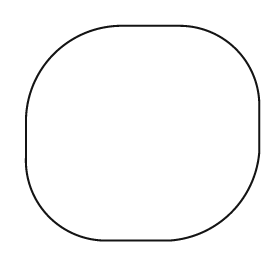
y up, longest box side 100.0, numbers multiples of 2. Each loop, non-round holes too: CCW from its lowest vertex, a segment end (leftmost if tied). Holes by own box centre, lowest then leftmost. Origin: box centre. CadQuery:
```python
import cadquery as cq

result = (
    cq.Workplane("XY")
    .moveTo(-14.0, -46.0)
    .lineTo(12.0, -46.0)
    .threePointArc((38.0, -34.0), (50.0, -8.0))
    .lineTo(50.0, 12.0)
    .threePointArc((40.0, 36.0), (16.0, 46.0))
    .lineTo(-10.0, 46.0)
    .threePointArc((-38.0, 34.0), (-50.0, 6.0))
    .lineTo(-50.0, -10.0)
    .threePointArc((-40.0, -36.0), (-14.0, -46.0))
    .close()
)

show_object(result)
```